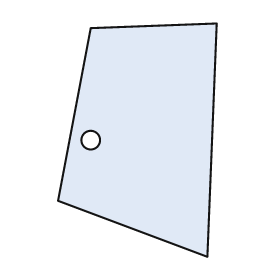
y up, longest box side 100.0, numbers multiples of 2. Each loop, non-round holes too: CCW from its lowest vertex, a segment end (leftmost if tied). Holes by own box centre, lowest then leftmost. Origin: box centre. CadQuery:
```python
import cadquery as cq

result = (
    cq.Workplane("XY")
    .moveTo(30.0, -50.0)
    .lineTo(34.0, 50.0)
    .lineTo(-20.0, 48.0)
    .lineTo(-34.0, -26.0)
    .close()
    .moveTo(-20.0, 0.0)
    .circle(4.0)
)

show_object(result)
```